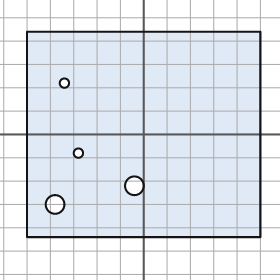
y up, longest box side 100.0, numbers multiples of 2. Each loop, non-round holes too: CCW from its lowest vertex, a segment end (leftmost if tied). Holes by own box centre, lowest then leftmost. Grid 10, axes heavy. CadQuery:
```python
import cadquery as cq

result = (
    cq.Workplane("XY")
    .moveTo(-50.0, -44.0)
    .lineTo(50.0, -44.0)
    .lineTo(50.0, 44.0)
    .lineTo(-50.0, 44.0)
    .close()
    .moveTo(-38.0, -30.0)
    .circle(4.0)
    .moveTo(-4.0, -22.0)
    .circle(4.0)
    .moveTo(-28.0, -8.0)
    .circle(2.0)
    .moveTo(-34.0, 22.0)
    .circle(2.0)
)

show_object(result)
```